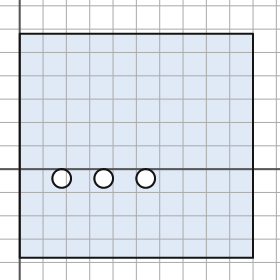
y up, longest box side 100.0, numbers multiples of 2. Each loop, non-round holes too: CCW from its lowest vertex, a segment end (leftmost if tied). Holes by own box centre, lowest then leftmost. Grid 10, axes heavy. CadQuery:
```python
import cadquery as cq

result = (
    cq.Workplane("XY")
    .moveTo(0.0, -38.0)
    .lineTo(100.0, -38.0)
    .lineTo(100.0, 58.0)
    .lineTo(0.0, 58.0)
    .close()
    .moveTo(18.0, -4.0)
    .circle(4.0)
    .moveTo(36.0, -4.0)
    .circle(4.0)
    .moveTo(54.0, -4.0)
    .circle(4.0)
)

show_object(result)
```